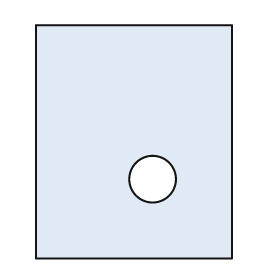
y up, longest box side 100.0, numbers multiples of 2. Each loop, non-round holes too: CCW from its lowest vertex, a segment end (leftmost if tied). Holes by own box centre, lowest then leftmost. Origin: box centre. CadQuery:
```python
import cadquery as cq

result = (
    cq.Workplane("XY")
    .moveTo(-42.0, -50.0)
    .lineTo(42.0, -50.0)
    .lineTo(42.0, 50.0)
    .lineTo(-42.0, 50.0)
    .close()
    .moveTo(8.0, -16.0)
    .circle(10.0)
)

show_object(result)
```